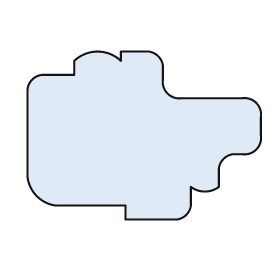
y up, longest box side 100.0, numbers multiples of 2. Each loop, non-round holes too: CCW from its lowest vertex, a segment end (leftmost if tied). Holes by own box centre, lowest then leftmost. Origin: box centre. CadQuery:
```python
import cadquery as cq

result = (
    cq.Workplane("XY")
    .moveTo(-8.0, -36.0)
    .lineTo(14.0, -36.0)
    .threePointArc((18.0, -34.0), (20.0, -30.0))
    .lineTo(20.0, -22.0)
    .threePointArc((26.0, -24.0), (32.0, -22.0))
    .lineTo(32.0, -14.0)
    .threePointArc((34.0, -10.0), (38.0, -8.0))
    .lineTo(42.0, -8.0)
    .threePointArc((48.0, -6.0), (50.0, 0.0))
    .lineTo(50.0, 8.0)
    .threePointArc((48.0, 14.0), (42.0, 16.0))
    .lineTo(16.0, 16.0)
    .threePointArc((10.0, 18.0), (8.0, 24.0))
    .lineTo(8.0, 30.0)
    .threePointArc((6.0, 34.0), (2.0, 36.0))
    .lineTo(-10.0, 36.0)
    .lineTo(-10.0, 32.0)
    .threePointArc((-20.0, 36.0), (-30.0, 32.0))
    .lineTo(-30.0, 26.0)
    .lineTo(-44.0, 26.0)
    .threePointArc((-48.0, 24.0), (-50.0, 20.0))
    .lineTo(-50.0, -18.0)
    .threePointArc((-46.0, -26.0), (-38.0, -30.0))
    .lineTo(-8.0, -30.0)
    .close()
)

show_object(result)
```